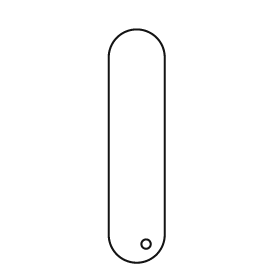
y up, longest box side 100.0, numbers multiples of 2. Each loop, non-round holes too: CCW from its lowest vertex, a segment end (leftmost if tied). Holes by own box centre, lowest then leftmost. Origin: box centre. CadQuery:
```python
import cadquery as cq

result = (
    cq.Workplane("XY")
    .moveTo(-12.0, -38.0)
    .threePointArc((0.0, -50.0), (12.0, -38.0))
    .lineTo(12.0, 38.0)
    .threePointArc((0.0, 50.0), (-12.0, 38.0))
    .close()
    .moveTo(4.0, -42.0)
    .circle(2.0)
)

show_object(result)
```